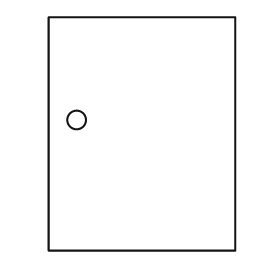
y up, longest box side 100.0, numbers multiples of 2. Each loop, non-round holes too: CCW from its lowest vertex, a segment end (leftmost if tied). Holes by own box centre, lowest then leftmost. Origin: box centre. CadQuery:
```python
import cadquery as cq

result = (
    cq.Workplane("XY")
    .moveTo(-40.0, -50.0)
    .lineTo(40.0, -50.0)
    .lineTo(40.0, 50.0)
    .lineTo(-40.0, 50.0)
    .close()
    .moveTo(-28.0, 6.0)
    .circle(4.0)
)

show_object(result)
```